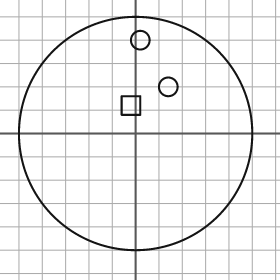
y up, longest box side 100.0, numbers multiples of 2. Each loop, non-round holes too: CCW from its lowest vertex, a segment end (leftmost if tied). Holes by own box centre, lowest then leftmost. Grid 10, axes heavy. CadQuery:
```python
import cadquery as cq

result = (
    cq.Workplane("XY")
    .moveTo(0.0, 0.0)
    .circle(50.0)
    .moveTo(-6.0, 8.0)
    .lineTo(2.0, 8.0)
    .lineTo(2.0, 16.0)
    .lineTo(-6.0, 16.0)
    .close()
    .moveTo(14.0, 20.0)
    .circle(4.0)
    .moveTo(2.0, 40.0)
    .circle(4.0)
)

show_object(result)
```